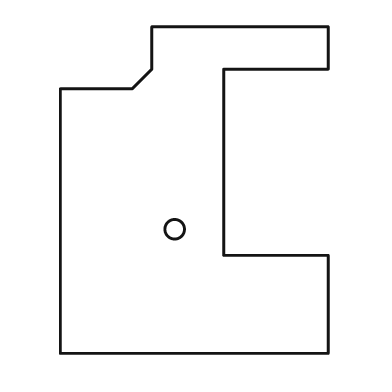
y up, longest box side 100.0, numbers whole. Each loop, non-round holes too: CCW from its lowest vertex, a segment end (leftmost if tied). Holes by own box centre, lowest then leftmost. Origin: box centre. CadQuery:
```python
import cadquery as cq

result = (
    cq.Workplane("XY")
    .moveTo(-41.0, -50.0)
    .lineTo(41.0, -50.0)
    .lineTo(41.0, -20.0)
    .lineTo(9.0, -20.0)
    .lineTo(9.0, 37.0)
    .lineTo(41.0, 37.0)
    .lineTo(41.0, 50.0)
    .lineTo(-13.0, 50.0)
    .lineTo(-13.0, 37.0)
    .lineTo(-19.0, 31.0)
    .lineTo(-41.0, 31.0)
    .close()
    .moveTo(-6.0, -12.0)
    .circle(3.0)
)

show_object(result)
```